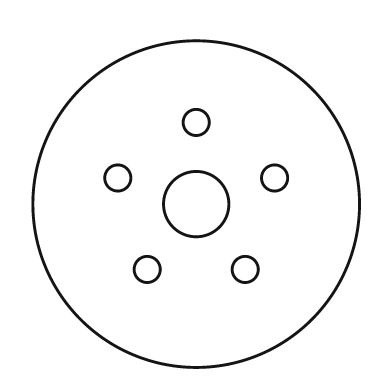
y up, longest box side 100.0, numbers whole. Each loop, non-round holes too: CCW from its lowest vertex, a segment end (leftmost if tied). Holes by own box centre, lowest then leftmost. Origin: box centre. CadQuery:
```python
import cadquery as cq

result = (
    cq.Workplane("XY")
    .moveTo(0.0, 0.0)
    .circle(50.0)
    .moveTo(-15.0, -20.0)
    .circle(4.0)
    .moveTo(15.0, -20.0)
    .circle(4.0)
    .moveTo(0.0, 0.0)
    .circle(10.0)
    .moveTo(-24.0, 8.0)
    .circle(4.0)
    .moveTo(24.0, 8.0)
    .circle(4.0)
    .moveTo(0.0, 25.0)
    .circle(4.0)
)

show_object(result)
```